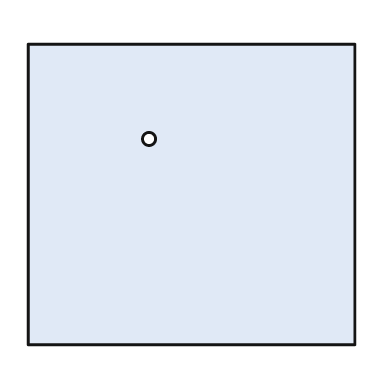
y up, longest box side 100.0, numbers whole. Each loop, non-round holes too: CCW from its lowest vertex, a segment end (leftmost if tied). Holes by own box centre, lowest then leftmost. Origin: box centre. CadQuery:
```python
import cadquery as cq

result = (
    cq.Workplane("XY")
    .moveTo(-50.0, -46.0)
    .lineTo(50.0, -46.0)
    .lineTo(50.0, 46.0)
    .lineTo(-50.0, 46.0)
    .close()
    .moveTo(-13.0, 17.0)
    .circle(2.0)
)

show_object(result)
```